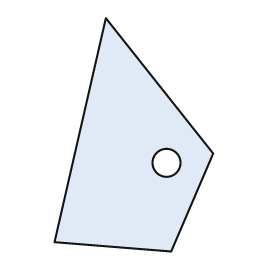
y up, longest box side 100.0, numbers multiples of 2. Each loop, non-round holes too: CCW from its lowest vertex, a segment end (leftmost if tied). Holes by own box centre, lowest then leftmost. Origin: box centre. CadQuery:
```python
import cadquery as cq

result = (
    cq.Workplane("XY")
    .moveTo(16.0, -50.0)
    .lineTo(34.0, -8.0)
    .lineTo(-12.0, 50.0)
    .lineTo(-34.0, -46.0)
    .close()
    .moveTo(14.0, -12.0)
    .circle(6.0)
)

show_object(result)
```